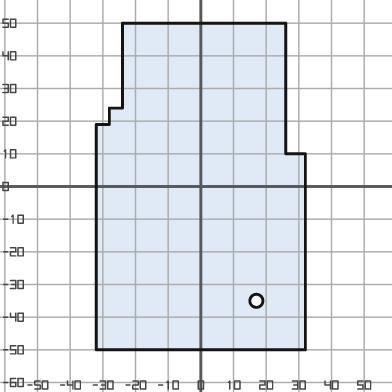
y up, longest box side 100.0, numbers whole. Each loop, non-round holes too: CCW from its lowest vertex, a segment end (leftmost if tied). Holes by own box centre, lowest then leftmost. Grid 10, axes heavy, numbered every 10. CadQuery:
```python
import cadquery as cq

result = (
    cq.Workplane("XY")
    .moveTo(-32.0, -50.0)
    .lineTo(32.0, -50.0)
    .lineTo(32.0, 10.0)
    .lineTo(26.0, 10.0)
    .lineTo(26.0, 50.0)
    .lineTo(-24.0, 50.0)
    .lineTo(-24.0, 24.0)
    .lineTo(-28.0, 24.0)
    .lineTo(-28.0, 19.0)
    .lineTo(-32.0, 19.0)
    .close()
    .moveTo(17.0, -35.0)
    .circle(2.0)
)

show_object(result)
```